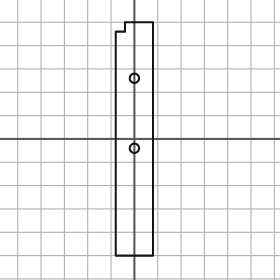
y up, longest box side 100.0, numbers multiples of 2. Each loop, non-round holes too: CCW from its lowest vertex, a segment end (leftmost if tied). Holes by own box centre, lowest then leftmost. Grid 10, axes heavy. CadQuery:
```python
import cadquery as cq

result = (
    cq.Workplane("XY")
    .moveTo(-8.0, -50.0)
    .lineTo(8.0, -50.0)
    .lineTo(8.0, 50.0)
    .lineTo(-4.0, 50.0)
    .lineTo(-4.0, 46.0)
    .lineTo(-8.0, 46.0)
    .close()
    .moveTo(0.0, -4.0)
    .circle(2.0)
    .moveTo(0.0, 26.0)
    .circle(2.0)
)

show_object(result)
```